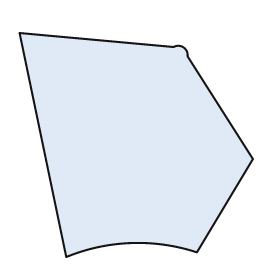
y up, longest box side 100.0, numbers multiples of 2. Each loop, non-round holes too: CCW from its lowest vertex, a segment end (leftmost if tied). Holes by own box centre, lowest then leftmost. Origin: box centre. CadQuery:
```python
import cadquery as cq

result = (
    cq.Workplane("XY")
    .moveTo(-30.0, -48.0)
    .threePointArc((-2.0, -42.0), (26.0, -46.0))
    .lineTo(50.0, -6.0)
    .lineTo(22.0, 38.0)
    .threePointArc((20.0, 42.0), (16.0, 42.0))
    .lineTo(-50.0, 48.0)
    .close()
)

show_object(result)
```